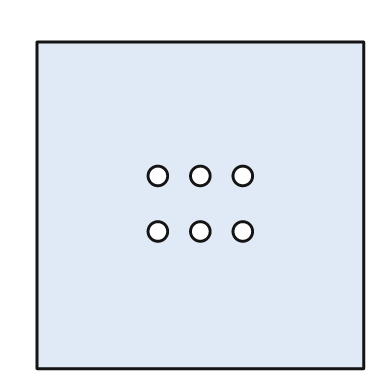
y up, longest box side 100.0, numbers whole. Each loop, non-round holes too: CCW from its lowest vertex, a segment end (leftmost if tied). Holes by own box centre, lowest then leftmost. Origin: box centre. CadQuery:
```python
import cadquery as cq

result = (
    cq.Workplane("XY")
    .moveTo(-50.0, -50.0)
    .lineTo(50.0, -50.0)
    .lineTo(50.0, 50.0)
    .lineTo(-50.0, 50.0)
    .close()
    .moveTo(-13.0, -8.0)
    .circle(3.0)
    .moveTo(0.0, -8.0)
    .circle(3.0)
    .moveTo(13.0, -8.0)
    .circle(3.0)
    .moveTo(-13.0, 9.0)
    .circle(3.0)
    .moveTo(0.0, 9.0)
    .circle(3.0)
    .moveTo(13.0, 9.0)
    .circle(3.0)
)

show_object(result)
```